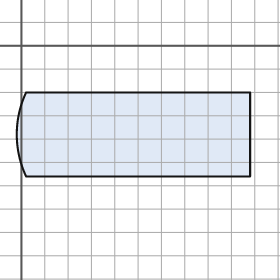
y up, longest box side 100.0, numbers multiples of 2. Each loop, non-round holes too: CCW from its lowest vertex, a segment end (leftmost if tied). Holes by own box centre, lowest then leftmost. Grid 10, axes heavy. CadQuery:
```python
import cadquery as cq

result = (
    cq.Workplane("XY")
    .moveTo(2.0, -56.0)
    .lineTo(98.0, -56.0)
    .lineTo(98.0, -20.0)
    .lineTo(2.0, -20.0)
    .threePointArc((-2.0, -38.0), (2.0, -56.0))
    .close()
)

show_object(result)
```